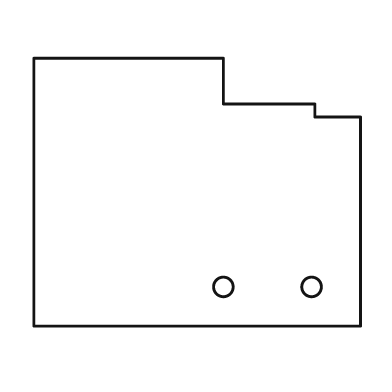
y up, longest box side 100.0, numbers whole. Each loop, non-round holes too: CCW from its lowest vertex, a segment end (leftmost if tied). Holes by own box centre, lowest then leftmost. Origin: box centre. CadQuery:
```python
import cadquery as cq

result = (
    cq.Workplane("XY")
    .moveTo(-50.0, -41.0)
    .lineTo(50.0, -41.0)
    .lineTo(50.0, 23.0)
    .lineTo(36.0, 23.0)
    .lineTo(36.0, 27.0)
    .lineTo(8.0, 27.0)
    .lineTo(8.0, 41.0)
    .lineTo(-50.0, 41.0)
    .close()
    .moveTo(8.0, -29.0)
    .circle(3.0)
    .moveTo(35.0, -29.0)
    .circle(3.0)
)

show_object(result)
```